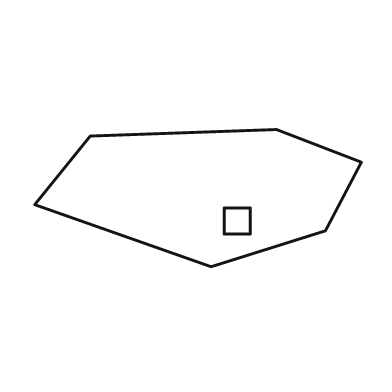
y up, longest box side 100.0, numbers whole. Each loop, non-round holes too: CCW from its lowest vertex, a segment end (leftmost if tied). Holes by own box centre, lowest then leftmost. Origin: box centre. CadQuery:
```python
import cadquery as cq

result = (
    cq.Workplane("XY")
    .moveTo(4.0, -21.0)
    .lineTo(39.0, -10.0)
    .lineTo(50.0, 11.0)
    .lineTo(24.0, 21.0)
    .lineTo(-33.0, 19.0)
    .lineTo(-50.0, -2.0)
    .close()
    .moveTo(8.0, -11.0)
    .lineTo(16.0, -11.0)
    .lineTo(16.0, -3.0)
    .lineTo(8.0, -3.0)
    .close()
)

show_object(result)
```